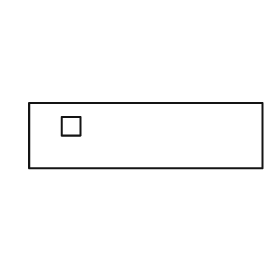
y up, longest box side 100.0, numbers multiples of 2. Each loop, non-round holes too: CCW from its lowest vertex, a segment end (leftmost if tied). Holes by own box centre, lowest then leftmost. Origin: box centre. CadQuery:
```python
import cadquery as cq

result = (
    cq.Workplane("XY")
    .moveTo(-50.0, -14.0)
    .lineTo(50.0, -14.0)
    .lineTo(50.0, 14.0)
    .lineTo(-50.0, 14.0)
    .close()
    .moveTo(-36.0, 0.0)
    .lineTo(-28.0, 0.0)
    .lineTo(-28.0, 8.0)
    .lineTo(-36.0, 8.0)
    .close()
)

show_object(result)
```